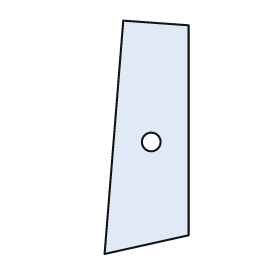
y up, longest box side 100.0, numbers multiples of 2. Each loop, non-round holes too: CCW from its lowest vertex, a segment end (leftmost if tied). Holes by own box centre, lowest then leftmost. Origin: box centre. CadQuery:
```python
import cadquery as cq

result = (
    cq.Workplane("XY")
    .moveTo(-18.0, -50.0)
    .lineTo(18.0, -42.0)
    .lineTo(18.0, 48.0)
    .lineTo(-10.0, 50.0)
    .close()
    .moveTo(2.0, -2.0)
    .circle(4.0)
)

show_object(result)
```